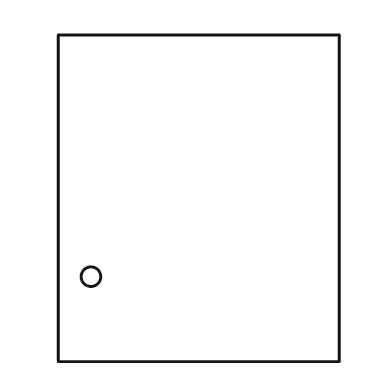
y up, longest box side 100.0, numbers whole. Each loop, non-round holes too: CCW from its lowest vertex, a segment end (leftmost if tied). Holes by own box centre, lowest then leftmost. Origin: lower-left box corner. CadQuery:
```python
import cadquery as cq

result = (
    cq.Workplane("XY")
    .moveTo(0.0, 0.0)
    .lineTo(86.0, 0.0)
    .lineTo(86.0, 100.0)
    .lineTo(0.0, 100.0)
    .close()
    .moveTo(10.0, 26.0)
    .circle(3.0)
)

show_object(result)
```